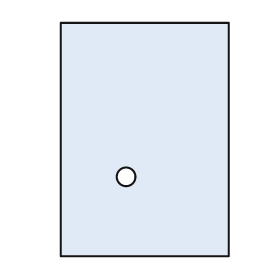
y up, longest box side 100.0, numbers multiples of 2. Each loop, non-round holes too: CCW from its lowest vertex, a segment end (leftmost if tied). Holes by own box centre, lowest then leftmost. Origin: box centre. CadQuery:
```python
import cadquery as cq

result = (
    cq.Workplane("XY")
    .moveTo(-36.0, -50.0)
    .lineTo(36.0, -50.0)
    .lineTo(36.0, 50.0)
    .lineTo(-36.0, 50.0)
    .close()
    .moveTo(-8.0, -16.0)
    .circle(4.0)
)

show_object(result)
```